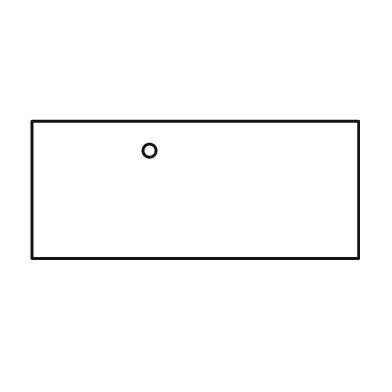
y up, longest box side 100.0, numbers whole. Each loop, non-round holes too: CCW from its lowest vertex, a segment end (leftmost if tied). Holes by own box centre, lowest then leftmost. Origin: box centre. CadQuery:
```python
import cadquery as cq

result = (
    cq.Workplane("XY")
    .moveTo(-50.0, -21.0)
    .lineTo(50.0, -21.0)
    .lineTo(50.0, 21.0)
    .lineTo(-50.0, 21.0)
    .close()
    .moveTo(-14.0, 12.0)
    .circle(2.0)
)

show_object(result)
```